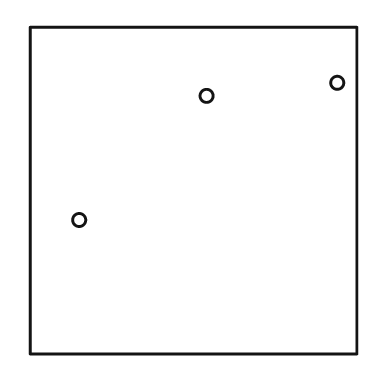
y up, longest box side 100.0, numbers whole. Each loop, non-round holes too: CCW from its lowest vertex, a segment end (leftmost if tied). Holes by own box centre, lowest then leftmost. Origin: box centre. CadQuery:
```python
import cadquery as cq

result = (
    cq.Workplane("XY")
    .moveTo(-50.0, -50.0)
    .lineTo(50.0, -50.0)
    .lineTo(50.0, 50.0)
    .lineTo(-50.0, 50.0)
    .close()
    .moveTo(-35.0, -9.0)
    .circle(2.0)
    .moveTo(4.0, 29.0)
    .circle(2.0)
    .moveTo(44.0, 33.0)
    .circle(2.0)
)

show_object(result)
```